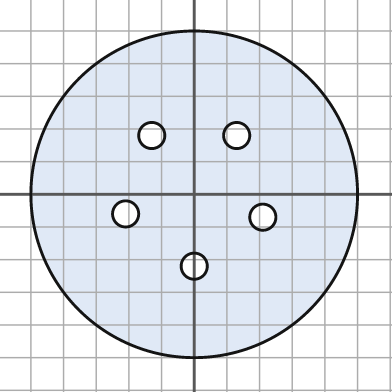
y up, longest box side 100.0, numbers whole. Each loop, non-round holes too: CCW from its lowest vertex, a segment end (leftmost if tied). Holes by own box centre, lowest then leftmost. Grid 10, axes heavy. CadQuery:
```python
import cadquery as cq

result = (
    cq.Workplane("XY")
    .moveTo(0.0, 0.0)
    .circle(50.0)
    .moveTo(0.0, -22.0)
    .circle(4.0)
    .moveTo(21.0, -7.0)
    .circle(4.0)
    .moveTo(-21.0, -6.0)
    .circle(4.0)
    .moveTo(-13.0, 18.0)
    .circle(4.0)
    .moveTo(13.0, 18.0)
    .circle(4.0)
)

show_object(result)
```